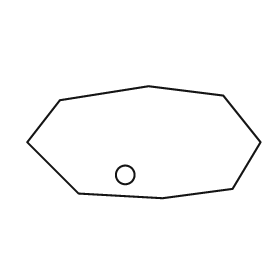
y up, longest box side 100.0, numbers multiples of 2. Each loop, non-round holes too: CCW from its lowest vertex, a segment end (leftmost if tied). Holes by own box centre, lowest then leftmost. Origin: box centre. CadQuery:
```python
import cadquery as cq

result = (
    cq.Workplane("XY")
    .moveTo(8.0, -24.0)
    .lineTo(38.0, -20.0)
    .lineTo(50.0, 0.0)
    .lineTo(34.0, 20.0)
    .lineTo(2.0, 24.0)
    .lineTo(-36.0, 18.0)
    .lineTo(-50.0, 0.0)
    .lineTo(-28.0, -22.0)
    .close()
    .moveTo(-8.0, -14.0)
    .circle(4.0)
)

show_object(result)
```